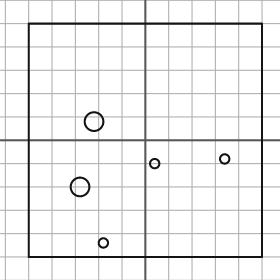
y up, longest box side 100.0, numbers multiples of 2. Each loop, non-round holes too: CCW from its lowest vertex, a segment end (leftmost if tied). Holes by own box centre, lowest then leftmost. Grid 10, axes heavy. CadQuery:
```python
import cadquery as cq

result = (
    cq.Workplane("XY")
    .moveTo(-50.0, -50.0)
    .lineTo(50.0, -50.0)
    .lineTo(50.0, 50.0)
    .lineTo(-50.0, 50.0)
    .close()
    .moveTo(-18.0, -44.0)
    .circle(2.0)
    .moveTo(-28.0, -20.0)
    .circle(4.0)
    .moveTo(4.0, -10.0)
    .circle(2.0)
    .moveTo(34.0, -8.0)
    .circle(2.0)
    .moveTo(-22.0, 8.0)
    .circle(4.0)
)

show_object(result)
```